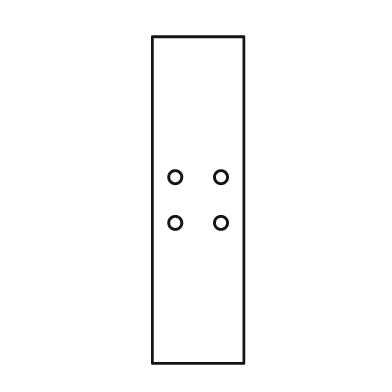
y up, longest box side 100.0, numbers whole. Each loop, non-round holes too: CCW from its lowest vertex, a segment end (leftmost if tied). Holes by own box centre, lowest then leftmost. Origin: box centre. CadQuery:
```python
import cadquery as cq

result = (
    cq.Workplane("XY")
    .moveTo(-14.0, -50.0)
    .lineTo(14.0, -50.0)
    .lineTo(14.0, 50.0)
    .lineTo(-14.0, 50.0)
    .close()
    .moveTo(-7.0, -7.0)
    .circle(2.0)
    .moveTo(7.0, -7.0)
    .circle(2.0)
    .moveTo(-7.0, 7.0)
    .circle(2.0)
    .moveTo(7.0, 7.0)
    .circle(2.0)
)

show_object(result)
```